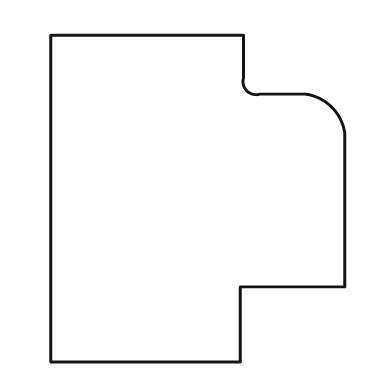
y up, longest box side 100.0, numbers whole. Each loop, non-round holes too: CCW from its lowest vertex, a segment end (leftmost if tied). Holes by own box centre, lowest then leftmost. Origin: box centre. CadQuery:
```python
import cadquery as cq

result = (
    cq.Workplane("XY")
    .moveTo(-45.0, -50.0)
    .lineTo(13.0, -50.0)
    .lineTo(13.0, -27.0)
    .lineTo(45.0, -27.0)
    .lineTo(45.0, 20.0)
    .threePointArc((41.0, 28.0), (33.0, 32.0))
    .lineTo(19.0, 32.0)
    .threePointArc((15.0, 33.0), (14.0, 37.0))
    .lineTo(14.0, 50.0)
    .lineTo(-45.0, 50.0)
    .close()
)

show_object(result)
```